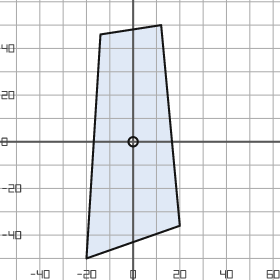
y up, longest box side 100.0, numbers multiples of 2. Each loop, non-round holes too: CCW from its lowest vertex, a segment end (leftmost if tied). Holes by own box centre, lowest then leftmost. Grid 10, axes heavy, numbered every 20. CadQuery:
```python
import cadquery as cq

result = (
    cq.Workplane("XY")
    .moveTo(-20.0, -50.0)
    .lineTo(20.0, -36.0)
    .lineTo(12.0, 50.0)
    .lineTo(-14.0, 46.0)
    .close()
    .moveTo(0.0, 0.0)
    .circle(2.0)
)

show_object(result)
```